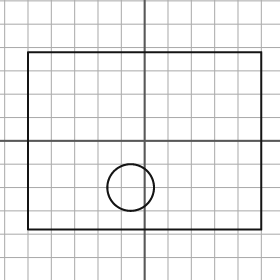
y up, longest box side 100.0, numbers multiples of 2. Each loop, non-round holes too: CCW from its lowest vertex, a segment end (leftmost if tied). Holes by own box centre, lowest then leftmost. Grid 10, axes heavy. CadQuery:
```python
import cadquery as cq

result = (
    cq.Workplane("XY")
    .moveTo(-50.0, -38.0)
    .lineTo(50.0, -38.0)
    .lineTo(50.0, 38.0)
    .lineTo(-50.0, 38.0)
    .close()
    .moveTo(-6.0, -20.0)
    .circle(10.0)
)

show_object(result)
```